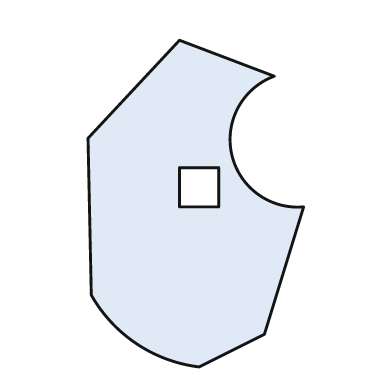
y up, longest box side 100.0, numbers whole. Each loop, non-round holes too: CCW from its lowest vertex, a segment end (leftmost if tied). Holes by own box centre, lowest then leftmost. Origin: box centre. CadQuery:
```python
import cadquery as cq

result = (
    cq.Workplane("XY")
    .moveTo(1.0, -50.0)
    .lineTo(21.0, -40.0)
    .lineTo(33.0, -1.0)
    .threePointArc((11.0, 15.0), (24.0, 39.0))
    .lineTo(-5.0, 50.0)
    .lineTo(-33.0, 20.0)
    .lineTo(-32.0, -28.0)
    .threePointArc((-18.0, -43.0), (1.0, -50.0))
    .close()
    .moveTo(-5.0, -1.0)
    .lineTo(7.0, -1.0)
    .lineTo(7.0, 11.0)
    .lineTo(-5.0, 11.0)
    .close()
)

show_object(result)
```